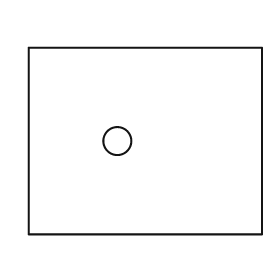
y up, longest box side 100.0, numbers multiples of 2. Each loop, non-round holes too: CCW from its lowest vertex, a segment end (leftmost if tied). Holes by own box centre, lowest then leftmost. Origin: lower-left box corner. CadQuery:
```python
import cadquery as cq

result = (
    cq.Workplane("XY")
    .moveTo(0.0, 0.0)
    .lineTo(100.0, 0.0)
    .lineTo(100.0, 80.0)
    .lineTo(0.0, 80.0)
    .close()
    .moveTo(38.0, 40.0)
    .circle(6.0)
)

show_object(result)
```